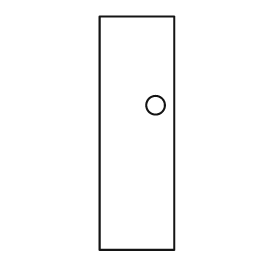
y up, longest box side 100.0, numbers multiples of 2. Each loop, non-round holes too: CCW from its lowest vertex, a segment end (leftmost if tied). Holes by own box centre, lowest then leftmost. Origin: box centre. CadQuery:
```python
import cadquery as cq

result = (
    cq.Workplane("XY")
    .moveTo(-16.0, -50.0)
    .lineTo(16.0, -50.0)
    .lineTo(16.0, 50.0)
    .lineTo(-16.0, 50.0)
    .close()
    .moveTo(8.0, 12.0)
    .circle(4.0)
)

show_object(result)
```